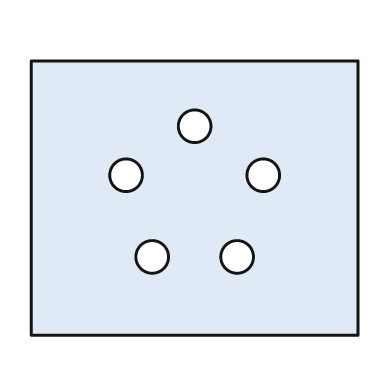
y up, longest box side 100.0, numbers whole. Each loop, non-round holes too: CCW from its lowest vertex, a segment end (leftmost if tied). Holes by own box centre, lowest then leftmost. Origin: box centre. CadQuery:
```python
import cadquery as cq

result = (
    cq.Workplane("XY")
    .moveTo(-50.0, -42.0)
    .lineTo(50.0, -42.0)
    .lineTo(50.0, 42.0)
    .lineTo(-50.0, 42.0)
    .close()
    .moveTo(-13.0, -18.0)
    .circle(5.0)
    .moveTo(13.0, -18.0)
    .circle(5.0)
    .moveTo(-21.0, 7.0)
    .circle(5.0)
    .moveTo(21.0, 7.0)
    .circle(5.0)
    .moveTo(0.0, 22.0)
    .circle(5.0)
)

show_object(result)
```